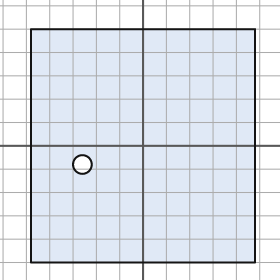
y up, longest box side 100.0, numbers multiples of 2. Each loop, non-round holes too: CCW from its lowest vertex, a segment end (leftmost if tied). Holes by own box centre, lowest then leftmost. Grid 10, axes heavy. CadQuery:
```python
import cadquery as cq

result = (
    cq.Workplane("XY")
    .moveTo(-48.0, -50.0)
    .lineTo(48.0, -50.0)
    .lineTo(48.0, 50.0)
    .lineTo(-48.0, 50.0)
    .close()
    .moveTo(-26.0, -8.0)
    .circle(4.0)
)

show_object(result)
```